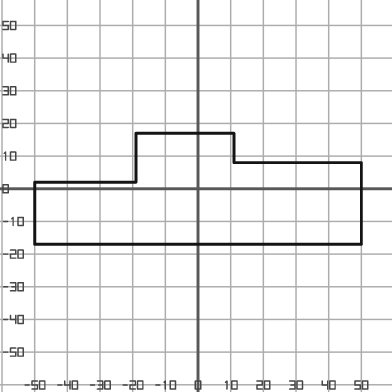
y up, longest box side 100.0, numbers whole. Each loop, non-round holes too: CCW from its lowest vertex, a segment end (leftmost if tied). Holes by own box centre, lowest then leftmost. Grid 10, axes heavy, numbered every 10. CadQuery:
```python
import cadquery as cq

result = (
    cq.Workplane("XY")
    .moveTo(-50.0, -17.0)
    .lineTo(50.0, -17.0)
    .lineTo(50.0, 8.0)
    .lineTo(11.0, 8.0)
    .lineTo(11.0, 17.0)
    .lineTo(-19.0, 17.0)
    .lineTo(-19.0, 2.0)
    .lineTo(-50.0, 2.0)
    .close()
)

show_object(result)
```